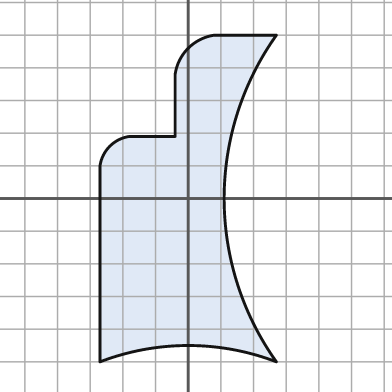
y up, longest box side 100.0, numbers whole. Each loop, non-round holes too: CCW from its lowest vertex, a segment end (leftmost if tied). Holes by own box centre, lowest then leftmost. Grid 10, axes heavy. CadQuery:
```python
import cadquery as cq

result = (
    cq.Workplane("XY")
    .moveTo(-27.0, -50.0)
    .threePointArc((0.0, -45.0), (27.0, -50.0))
    .threePointArc((11.0, 0.0), (27.0, 50.0))
    .lineTo(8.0, 50.0)
    .threePointArc((0.0, 46.0), (-4.0, 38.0))
    .lineTo(-4.0, 19.0)
    .lineTo(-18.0, 19.0)
    .threePointArc((-24.0, 16.0), (-27.0, 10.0))
    .close()
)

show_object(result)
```